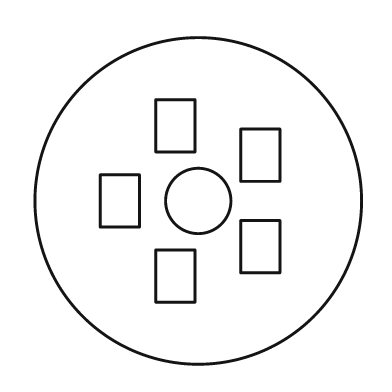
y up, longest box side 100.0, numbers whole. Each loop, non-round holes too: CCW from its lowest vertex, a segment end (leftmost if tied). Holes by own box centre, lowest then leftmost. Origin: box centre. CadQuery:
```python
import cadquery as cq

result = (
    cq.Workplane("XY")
    .moveTo(0.0, 0.0)
    .circle(50.0)
    .moveTo(-13.0, -31.0)
    .lineTo(-1.0, -31.0)
    .lineTo(-1.0, -15.0)
    .lineTo(-13.0, -15.0)
    .close()
    .moveTo(13.0, -22.0)
    .lineTo(25.0, -22.0)
    .lineTo(25.0, -6.0)
    .lineTo(13.0, -6.0)
    .close()
    .moveTo(-30.0, -8.0)
    .lineTo(-18.0, -8.0)
    .lineTo(-18.0, 8.0)
    .lineTo(-30.0, 8.0)
    .close()
    .moveTo(0.0, 0.0)
    .circle(10.0)
    .moveTo(13.0, 6.0)
    .lineTo(25.0, 6.0)
    .lineTo(25.0, 22.0)
    .lineTo(13.0, 22.0)
    .close()
    .moveTo(-13.0, 15.0)
    .lineTo(-1.0, 15.0)
    .lineTo(-1.0, 31.0)
    .lineTo(-13.0, 31.0)
    .close()
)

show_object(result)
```